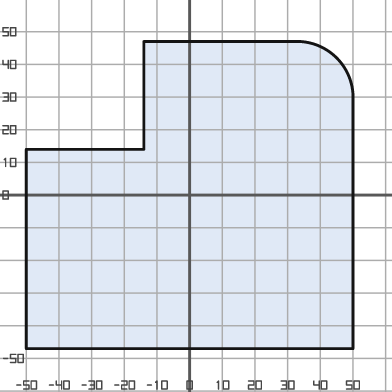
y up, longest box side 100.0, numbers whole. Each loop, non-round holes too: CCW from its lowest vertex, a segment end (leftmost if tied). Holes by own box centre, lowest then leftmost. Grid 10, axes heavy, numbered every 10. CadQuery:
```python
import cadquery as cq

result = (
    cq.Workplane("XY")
    .moveTo(-50.0, -47.0)
    .lineTo(50.0, -47.0)
    .lineTo(50.0, 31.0)
    .threePointArc((45.0, 42.0), (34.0, 47.0))
    .lineTo(-14.0, 47.0)
    .lineTo(-14.0, 14.0)
    .lineTo(-50.0, 14.0)
    .close()
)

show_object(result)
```